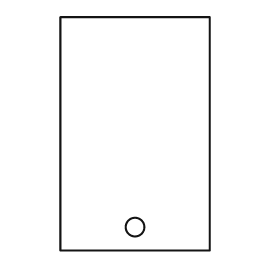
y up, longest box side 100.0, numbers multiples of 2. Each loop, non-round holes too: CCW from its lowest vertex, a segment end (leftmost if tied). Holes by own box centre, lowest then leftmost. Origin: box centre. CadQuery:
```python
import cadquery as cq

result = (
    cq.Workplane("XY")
    .moveTo(-32.0, -50.0)
    .lineTo(32.0, -50.0)
    .lineTo(32.0, 50.0)
    .lineTo(-32.0, 50.0)
    .close()
    .moveTo(0.0, -40.0)
    .circle(4.0)
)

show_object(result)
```